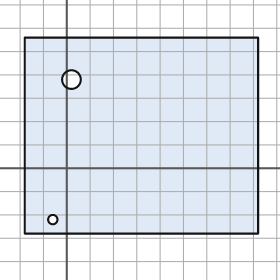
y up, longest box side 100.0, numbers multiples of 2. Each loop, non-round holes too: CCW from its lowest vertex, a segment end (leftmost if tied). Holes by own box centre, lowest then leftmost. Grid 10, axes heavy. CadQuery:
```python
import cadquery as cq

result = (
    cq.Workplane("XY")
    .moveTo(-18.0, -28.0)
    .lineTo(82.0, -28.0)
    .lineTo(82.0, 56.0)
    .lineTo(-18.0, 56.0)
    .close()
    .moveTo(-6.0, -22.0)
    .circle(2.0)
    .moveTo(2.0, 38.0)
    .circle(4.0)
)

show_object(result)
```